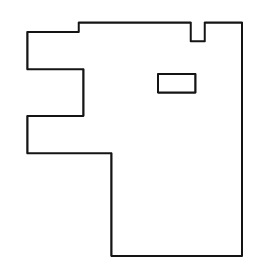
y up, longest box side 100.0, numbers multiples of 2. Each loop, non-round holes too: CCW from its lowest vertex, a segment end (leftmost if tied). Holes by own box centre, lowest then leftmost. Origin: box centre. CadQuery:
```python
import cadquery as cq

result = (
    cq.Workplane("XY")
    .moveTo(-10.0, -50.0)
    .lineTo(46.0, -50.0)
    .lineTo(46.0, 50.0)
    .lineTo(30.0, 50.0)
    .lineTo(30.0, 42.0)
    .lineTo(24.0, 42.0)
    .lineTo(24.0, 50.0)
    .lineTo(-24.0, 50.0)
    .lineTo(-24.0, 46.0)
    .lineTo(-46.0, 46.0)
    .lineTo(-46.0, 30.0)
    .lineTo(-22.0, 30.0)
    .lineTo(-22.0, 10.0)
    .lineTo(-46.0, 10.0)
    .lineTo(-46.0, -6.0)
    .lineTo(-10.0, -6.0)
    .close()
    .moveTo(10.0, 20.0)
    .lineTo(26.0, 20.0)
    .lineTo(26.0, 28.0)
    .lineTo(10.0, 28.0)
    .close()
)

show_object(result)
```